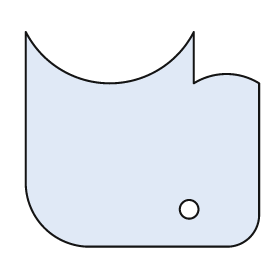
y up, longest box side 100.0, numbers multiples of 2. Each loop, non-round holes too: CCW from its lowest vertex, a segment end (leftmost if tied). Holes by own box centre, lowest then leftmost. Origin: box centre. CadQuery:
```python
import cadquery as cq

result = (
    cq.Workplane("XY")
    .moveTo(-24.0, -46.0)
    .lineTo(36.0, -46.0)
    .threePointArc((46.0, -42.0), (50.0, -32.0))
    .lineTo(50.0, 24.0)
    .threePointArc((36.0, 28.0), (22.0, 24.0))
    .lineTo(22.0, 46.0)
    .threePointArc((-14.0, 24.0), (-50.0, 46.0))
    .lineTo(-50.0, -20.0)
    .threePointArc((-42.0, -38.0), (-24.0, -46.0))
    .close()
    .moveTo(20.0, -30.0)
    .circle(4.0)
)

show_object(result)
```